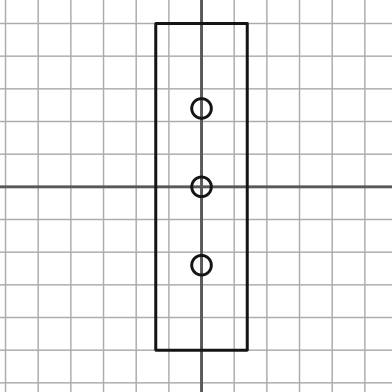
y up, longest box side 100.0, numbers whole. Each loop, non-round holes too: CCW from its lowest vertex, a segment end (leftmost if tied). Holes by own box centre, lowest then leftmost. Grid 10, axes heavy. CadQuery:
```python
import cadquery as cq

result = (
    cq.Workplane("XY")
    .moveTo(-14.0, -50.0)
    .lineTo(14.0, -50.0)
    .lineTo(14.0, 50.0)
    .lineTo(-14.0, 50.0)
    .close()
    .moveTo(0.0, -24.0)
    .circle(3.0)
    .moveTo(0.0, 0.0)
    .circle(3.0)
    .moveTo(0.0, 24.0)
    .circle(3.0)
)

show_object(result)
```